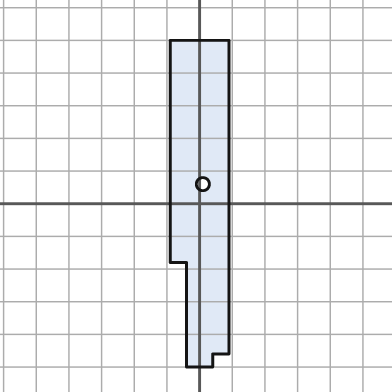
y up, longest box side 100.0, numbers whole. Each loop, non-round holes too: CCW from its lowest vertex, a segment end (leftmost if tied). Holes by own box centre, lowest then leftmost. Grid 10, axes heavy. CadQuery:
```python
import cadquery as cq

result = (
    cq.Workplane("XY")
    .moveTo(-4.0, -50.0)
    .lineTo(4.0, -50.0)
    .lineTo(4.0, -46.0)
    .lineTo(9.0, -46.0)
    .lineTo(9.0, 50.0)
    .lineTo(-9.0, 50.0)
    .lineTo(-9.0, -18.0)
    .lineTo(-4.0, -18.0)
    .close()
    .moveTo(1.0, 6.0)
    .circle(2.0)
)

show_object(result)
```